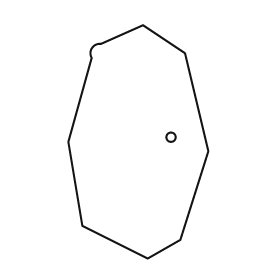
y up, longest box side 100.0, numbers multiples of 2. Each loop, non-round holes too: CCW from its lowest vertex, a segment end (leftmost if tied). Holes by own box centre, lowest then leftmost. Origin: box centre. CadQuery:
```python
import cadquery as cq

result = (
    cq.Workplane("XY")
    .moveTo(4.0, -50.0)
    .lineTo(18.0, -42.0)
    .lineTo(30.0, -4.0)
    .lineTo(20.0, 38.0)
    .lineTo(2.0, 50.0)
    .lineTo(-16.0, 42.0)
    .threePointArc((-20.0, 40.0), (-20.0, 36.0))
    .lineTo(-30.0, 0.0)
    .lineTo(-24.0, -36.0)
    .close()
    .moveTo(14.0, 2.0)
    .circle(2.0)
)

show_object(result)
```